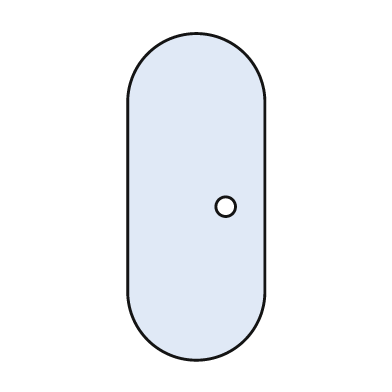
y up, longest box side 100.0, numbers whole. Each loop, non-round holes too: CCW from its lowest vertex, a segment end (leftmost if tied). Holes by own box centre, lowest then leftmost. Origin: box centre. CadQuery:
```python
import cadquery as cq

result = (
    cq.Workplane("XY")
    .moveTo(-21.0, -29.0)
    .threePointArc((0.0, -50.0), (21.0, -29.0))
    .lineTo(21.0, 29.0)
    .threePointArc((0.0, 50.0), (-21.0, 29.0))
    .close()
    .moveTo(9.0, -3.0)
    .circle(3.0)
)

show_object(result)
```